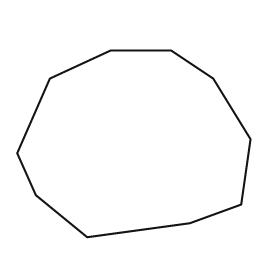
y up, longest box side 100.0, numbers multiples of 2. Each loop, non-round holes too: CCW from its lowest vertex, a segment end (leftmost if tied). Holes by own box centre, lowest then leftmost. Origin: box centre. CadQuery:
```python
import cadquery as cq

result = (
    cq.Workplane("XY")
    .moveTo(-20.0, -40.0)
    .lineTo(24.0, -34.0)
    .lineTo(46.0, -26.0)
    .lineTo(50.0, 2.0)
    .lineTo(34.0, 28.0)
    .lineTo(16.0, 40.0)
    .lineTo(-10.0, 40.0)
    .lineTo(-36.0, 28.0)
    .lineTo(-50.0, -4.0)
    .lineTo(-42.0, -22.0)
    .close()
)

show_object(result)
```